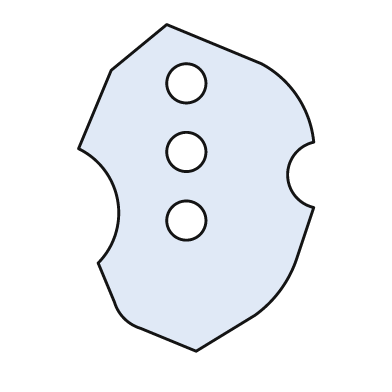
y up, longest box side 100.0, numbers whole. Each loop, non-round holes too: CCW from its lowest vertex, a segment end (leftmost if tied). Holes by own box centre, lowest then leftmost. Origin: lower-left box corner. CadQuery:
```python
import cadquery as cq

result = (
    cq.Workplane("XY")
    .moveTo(36.0, 0.0)
    .lineTo(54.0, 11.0)
    .threePointArc((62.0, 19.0), (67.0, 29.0))
    .lineTo(72.0, 44.0)
    .threePointArc((64.0, 54.0), (72.0, 64.0))
    .threePointArc((67.0, 78.0), (56.0, 88.0))
    .lineTo(27.0, 100.0)
    .lineTo(10.0, 86.0)
    .lineTo(0.0, 62.0)
    .threePointArc((12.0, 46.0), (6.0, 27.0))
    .lineTo(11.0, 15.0)
    .threePointArc((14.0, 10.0), (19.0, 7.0))
    .close()
    .moveTo(33.0, 40.0)
    .circle(6.0)
    .moveTo(33.0, 61.0)
    .circle(6.0)
    .moveTo(33.0, 82.0)
    .circle(6.0)
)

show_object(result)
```